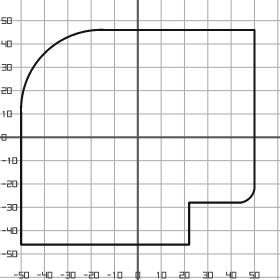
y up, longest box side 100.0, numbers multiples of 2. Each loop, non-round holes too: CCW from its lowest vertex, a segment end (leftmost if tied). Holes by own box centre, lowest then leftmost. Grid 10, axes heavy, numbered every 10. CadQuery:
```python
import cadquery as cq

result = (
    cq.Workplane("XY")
    .moveTo(-50.0, -46.0)
    .lineTo(22.0, -46.0)
    .lineTo(22.0, -28.0)
    .lineTo(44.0, -28.0)
    .threePointArc((48.0, -26.0), (50.0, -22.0))
    .lineTo(50.0, 46.0)
    .lineTo(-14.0, 46.0)
    .threePointArc((-40.0, 36.0), (-50.0, 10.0))
    .close()
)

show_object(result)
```